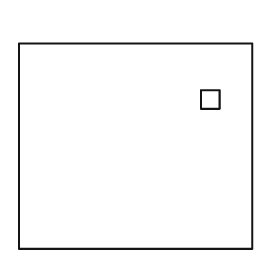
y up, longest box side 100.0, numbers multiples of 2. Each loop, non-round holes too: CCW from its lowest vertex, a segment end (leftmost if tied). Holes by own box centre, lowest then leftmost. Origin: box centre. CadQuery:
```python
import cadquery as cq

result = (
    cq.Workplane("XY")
    .moveTo(-50.0, -44.0)
    .lineTo(50.0, -44.0)
    .lineTo(50.0, 44.0)
    .lineTo(-50.0, 44.0)
    .close()
    .moveTo(28.0, 16.0)
    .lineTo(36.0, 16.0)
    .lineTo(36.0, 24.0)
    .lineTo(28.0, 24.0)
    .close()
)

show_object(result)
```